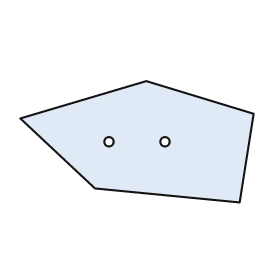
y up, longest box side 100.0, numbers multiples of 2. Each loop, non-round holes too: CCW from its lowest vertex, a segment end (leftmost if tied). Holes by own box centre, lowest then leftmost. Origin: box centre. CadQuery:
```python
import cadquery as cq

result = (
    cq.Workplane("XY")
    .moveTo(44.0, -26.0)
    .lineTo(50.0, 12.0)
    .lineTo(4.0, 26.0)
    .lineTo(-50.0, 10.0)
    .lineTo(-18.0, -20.0)
    .close()
    .moveTo(-12.0, 0.0)
    .circle(2.0)
    .moveTo(12.0, 0.0)
    .circle(2.0)
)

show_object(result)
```